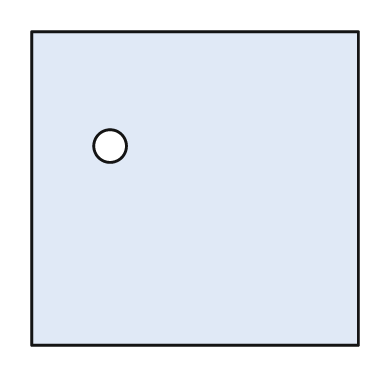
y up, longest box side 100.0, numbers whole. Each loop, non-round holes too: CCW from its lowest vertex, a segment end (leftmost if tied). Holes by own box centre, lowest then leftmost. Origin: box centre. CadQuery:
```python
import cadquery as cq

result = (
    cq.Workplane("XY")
    .moveTo(-50.0, -48.0)
    .lineTo(50.0, -48.0)
    .lineTo(50.0, 48.0)
    .lineTo(-50.0, 48.0)
    .close()
    .moveTo(-26.0, 13.0)
    .circle(5.0)
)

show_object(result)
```